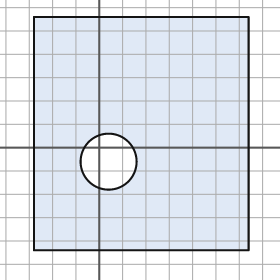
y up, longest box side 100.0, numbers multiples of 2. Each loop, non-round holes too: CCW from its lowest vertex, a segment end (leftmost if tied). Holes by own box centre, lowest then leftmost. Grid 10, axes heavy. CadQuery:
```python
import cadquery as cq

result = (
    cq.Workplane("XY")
    .moveTo(-28.0, -44.0)
    .lineTo(64.0, -44.0)
    .lineTo(64.0, 56.0)
    .lineTo(-28.0, 56.0)
    .close()
    .moveTo(4.0, -6.0)
    .circle(12.0)
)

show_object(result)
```